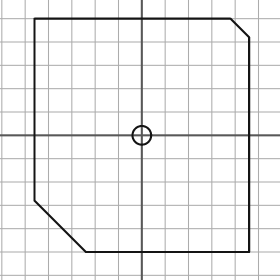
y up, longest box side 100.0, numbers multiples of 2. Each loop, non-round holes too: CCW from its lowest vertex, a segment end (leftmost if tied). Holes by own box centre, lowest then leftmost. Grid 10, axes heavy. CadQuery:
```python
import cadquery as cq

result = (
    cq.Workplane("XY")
    .moveTo(-24.0, -50.0)
    .lineTo(46.0, -50.0)
    .lineTo(46.0, 42.0)
    .lineTo(38.0, 50.0)
    .lineTo(-46.0, 50.0)
    .lineTo(-46.0, -28.0)
    .close()
    .moveTo(0.0, 0.0)
    .circle(4.0)
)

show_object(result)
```